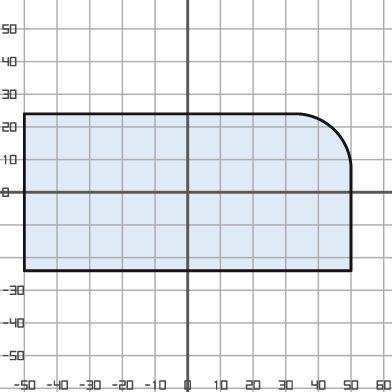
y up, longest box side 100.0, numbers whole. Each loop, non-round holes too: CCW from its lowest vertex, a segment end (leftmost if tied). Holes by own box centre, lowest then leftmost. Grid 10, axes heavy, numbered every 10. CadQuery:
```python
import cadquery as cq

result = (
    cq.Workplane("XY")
    .moveTo(-50.0, -24.0)
    .lineTo(50.0, -24.0)
    .lineTo(50.0, 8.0)
    .threePointArc((45.0, 19.0), (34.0, 24.0))
    .lineTo(-50.0, 24.0)
    .close()
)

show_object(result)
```